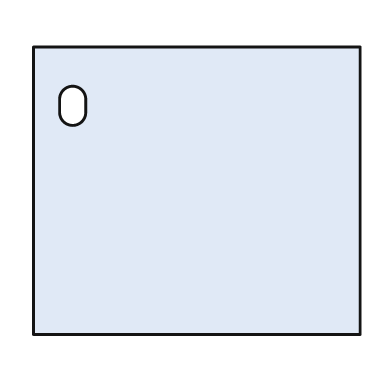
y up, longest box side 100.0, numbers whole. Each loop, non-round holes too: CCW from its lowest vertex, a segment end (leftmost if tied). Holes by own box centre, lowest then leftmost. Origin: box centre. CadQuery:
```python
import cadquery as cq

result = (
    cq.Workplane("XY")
    .moveTo(-50.0, -44.0)
    .lineTo(50.0, -44.0)
    .lineTo(50.0, 44.0)
    .lineTo(-50.0, 44.0)
    .close()
    .moveTo(-42.0, 24.0)
    .threePointArc((-38.0, 20.0), (-34.0, 24.0))
    .lineTo(-34.0, 28.0)
    .threePointArc((-38.0, 32.0), (-42.0, 28.0))
    .close()
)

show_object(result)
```